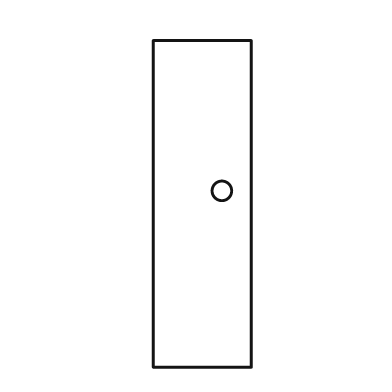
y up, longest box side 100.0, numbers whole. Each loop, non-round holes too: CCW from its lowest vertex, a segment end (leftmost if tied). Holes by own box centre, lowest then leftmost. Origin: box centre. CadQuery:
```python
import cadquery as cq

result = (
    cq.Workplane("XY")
    .moveTo(-15.0, -50.0)
    .lineTo(15.0, -50.0)
    .lineTo(15.0, 50.0)
    .lineTo(-15.0, 50.0)
    .close()
    .moveTo(6.0, 4.0)
    .circle(3.0)
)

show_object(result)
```